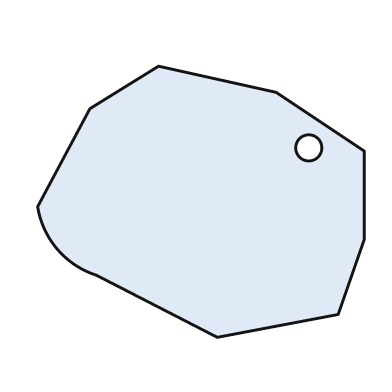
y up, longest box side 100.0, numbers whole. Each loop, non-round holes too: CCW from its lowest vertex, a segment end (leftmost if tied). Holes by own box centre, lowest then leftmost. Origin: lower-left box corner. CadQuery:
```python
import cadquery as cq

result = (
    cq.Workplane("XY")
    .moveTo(55.0, 0.0)
    .lineTo(92.0, 7.0)
    .lineTo(100.0, 30.0)
    .lineTo(100.0, 57.0)
    .lineTo(73.0, 75.0)
    .lineTo(37.0, 83.0)
    .lineTo(16.0, 70.0)
    .lineTo(0.0, 40.0)
    .threePointArc((6.0, 27.0), (18.0, 19.0))
    .close()
    .moveTo(83.0, 58.0)
    .circle(4.0)
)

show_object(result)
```